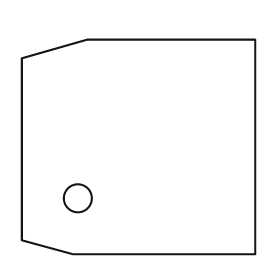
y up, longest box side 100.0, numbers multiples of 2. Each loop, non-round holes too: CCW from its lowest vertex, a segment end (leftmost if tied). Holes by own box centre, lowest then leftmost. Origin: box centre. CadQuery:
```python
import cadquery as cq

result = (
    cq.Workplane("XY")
    .moveTo(-28.0, -46.0)
    .lineTo(50.0, -46.0)
    .lineTo(50.0, 46.0)
    .lineTo(-22.0, 46.0)
    .lineTo(-50.0, 38.0)
    .lineTo(-50.0, -40.0)
    .close()
    .moveTo(-26.0, -22.0)
    .circle(6.0)
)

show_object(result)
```